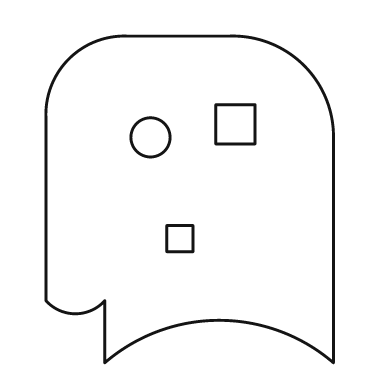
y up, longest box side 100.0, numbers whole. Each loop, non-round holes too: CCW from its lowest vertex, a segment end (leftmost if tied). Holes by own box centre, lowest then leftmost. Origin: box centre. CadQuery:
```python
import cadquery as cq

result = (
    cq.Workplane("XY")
    .moveTo(-26.0, -50.0)
    .threePointArc((9.0, -37.0), (44.0, -50.0))
    .lineTo(44.0, 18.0)
    .threePointArc((35.0, 41.0), (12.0, 50.0))
    .lineTo(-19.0, 50.0)
    .threePointArc((-37.0, 43.0), (-44.0, 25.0))
    .lineTo(-44.0, -31.0)
    .threePointArc((-35.0, -35.0), (-26.0, -31.0))
    .close()
    .moveTo(-7.0, -16.0)
    .lineTo(1.0, -16.0)
    .lineTo(1.0, -8.0)
    .lineTo(-7.0, -8.0)
    .close()
    .moveTo(-12.0, 19.0)
    .circle(6.0)
    .moveTo(8.0, 17.0)
    .lineTo(20.0, 17.0)
    .lineTo(20.0, 29.0)
    .lineTo(8.0, 29.0)
    .close()
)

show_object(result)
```